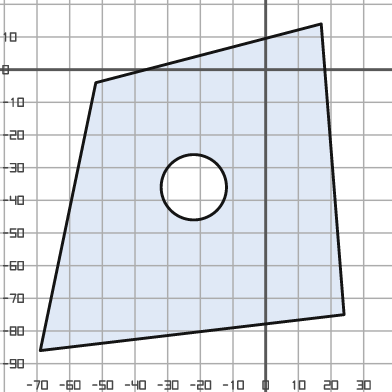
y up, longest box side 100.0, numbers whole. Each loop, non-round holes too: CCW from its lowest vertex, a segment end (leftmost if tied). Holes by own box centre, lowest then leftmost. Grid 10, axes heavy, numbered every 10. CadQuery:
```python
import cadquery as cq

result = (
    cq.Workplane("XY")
    .moveTo(-69.0, -86.0)
    .lineTo(24.0, -75.0)
    .lineTo(17.0, 14.0)
    .lineTo(-52.0, -4.0)
    .close()
    .moveTo(-22.0, -36.0)
    .circle(10.0)
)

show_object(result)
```